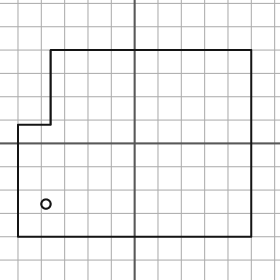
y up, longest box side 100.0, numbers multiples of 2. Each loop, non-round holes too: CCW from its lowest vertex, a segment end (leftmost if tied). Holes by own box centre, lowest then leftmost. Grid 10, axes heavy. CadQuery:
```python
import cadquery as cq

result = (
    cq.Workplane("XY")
    .moveTo(-50.0, -40.0)
    .lineTo(50.0, -40.0)
    .lineTo(50.0, 40.0)
    .lineTo(-36.0, 40.0)
    .lineTo(-36.0, 8.0)
    .lineTo(-50.0, 8.0)
    .close()
    .moveTo(-38.0, -26.0)
    .circle(2.0)
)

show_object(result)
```